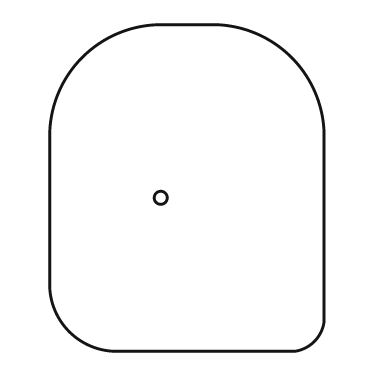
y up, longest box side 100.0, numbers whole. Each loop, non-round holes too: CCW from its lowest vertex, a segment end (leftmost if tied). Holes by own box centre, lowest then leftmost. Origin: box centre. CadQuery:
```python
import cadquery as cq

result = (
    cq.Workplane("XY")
    .moveTo(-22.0, -50.0)
    .lineTo(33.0, -50.0)
    .threePointArc((39.0, -47.0), (42.0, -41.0))
    .lineTo(42.0, 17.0)
    .threePointArc((32.0, 40.0), (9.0, 50.0))
    .lineTo(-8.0, 50.0)
    .threePointArc((-32.0, 40.0), (-42.0, 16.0))
    .lineTo(-42.0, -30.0)
    .threePointArc((-36.0, -44.0), (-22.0, -50.0))
    .close()
    .moveTo(-8.0, -3.0)
    .circle(2.0)
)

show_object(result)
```